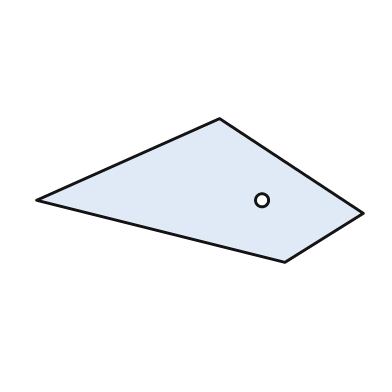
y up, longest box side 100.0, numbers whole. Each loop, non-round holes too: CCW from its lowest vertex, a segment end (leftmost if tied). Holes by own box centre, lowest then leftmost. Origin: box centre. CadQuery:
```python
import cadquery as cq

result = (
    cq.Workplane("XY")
    .moveTo(26.0, -22.0)
    .lineTo(50.0, -7.0)
    .lineTo(6.0, 22.0)
    .lineTo(-50.0, -3.0)
    .close()
    .moveTo(19.0, -3.0)
    .circle(2.0)
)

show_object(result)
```